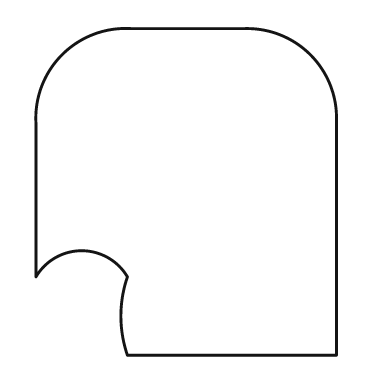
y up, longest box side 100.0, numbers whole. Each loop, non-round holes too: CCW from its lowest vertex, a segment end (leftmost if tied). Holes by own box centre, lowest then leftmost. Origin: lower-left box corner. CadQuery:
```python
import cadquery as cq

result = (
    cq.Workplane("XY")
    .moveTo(28.0, 0.0)
    .lineTo(92.0, 0.0)
    .lineTo(92.0, 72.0)
    .threePointArc((84.0, 92.0), (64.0, 100.0))
    .lineTo(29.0, 100.0)
    .threePointArc((8.0, 92.0), (0.0, 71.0))
    .lineTo(0.0, 24.0)
    .threePointArc((14.0, 32.0), (28.0, 24.0))
    .threePointArc((26.0, 12.0), (28.0, 0.0))
    .close()
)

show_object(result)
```